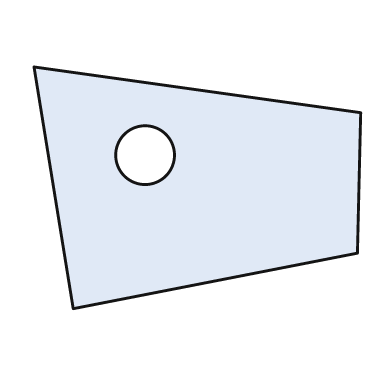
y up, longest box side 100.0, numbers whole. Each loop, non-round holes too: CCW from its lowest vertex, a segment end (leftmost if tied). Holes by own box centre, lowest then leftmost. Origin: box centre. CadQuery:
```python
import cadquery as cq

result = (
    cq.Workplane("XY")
    .moveTo(-38.0, -37.0)
    .lineTo(49.0, -20.0)
    .lineTo(50.0, 23.0)
    .lineTo(-50.0, 37.0)
    .close()
    .moveTo(-16.0, 10.0)
    .circle(9.0)
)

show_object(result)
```